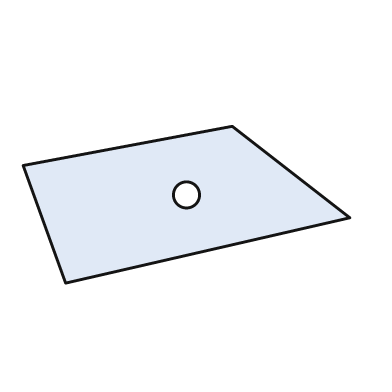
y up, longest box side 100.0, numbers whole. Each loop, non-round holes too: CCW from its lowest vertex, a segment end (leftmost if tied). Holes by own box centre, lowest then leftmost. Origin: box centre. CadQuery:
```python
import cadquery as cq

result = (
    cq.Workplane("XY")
    .moveTo(-37.0, -24.0)
    .lineTo(50.0, -4.0)
    .lineTo(14.0, 24.0)
    .lineTo(-50.0, 12.0)
    .close()
    .moveTo(0.0, 3.0)
    .circle(4.0)
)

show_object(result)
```